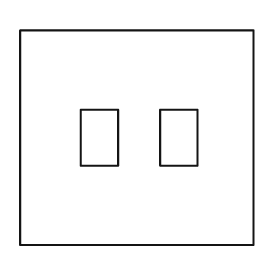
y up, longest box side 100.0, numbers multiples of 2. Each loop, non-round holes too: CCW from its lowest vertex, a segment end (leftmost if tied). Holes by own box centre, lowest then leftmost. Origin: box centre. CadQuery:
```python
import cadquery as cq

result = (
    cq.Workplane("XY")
    .moveTo(-50.0, -46.0)
    .lineTo(50.0, -46.0)
    .lineTo(50.0, 46.0)
    .lineTo(-50.0, 46.0)
    .close()
    .moveTo(-24.0, -12.0)
    .lineTo(-8.0, -12.0)
    .lineTo(-8.0, 12.0)
    .lineTo(-24.0, 12.0)
    .close()
    .moveTo(10.0, -12.0)
    .lineTo(26.0, -12.0)
    .lineTo(26.0, 12.0)
    .lineTo(10.0, 12.0)
    .close()
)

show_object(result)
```